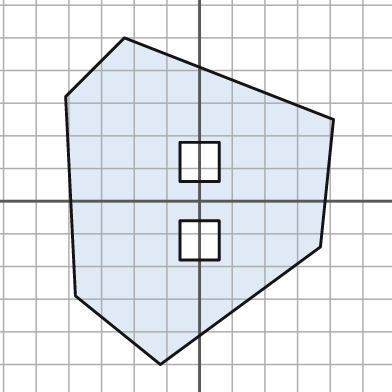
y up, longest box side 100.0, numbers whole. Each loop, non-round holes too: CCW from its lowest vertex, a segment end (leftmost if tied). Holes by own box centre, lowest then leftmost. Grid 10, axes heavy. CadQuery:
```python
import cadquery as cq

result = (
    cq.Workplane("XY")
    .moveTo(-12.0, -50.0)
    .lineTo(37.0, -14.0)
    .lineTo(41.0, 25.0)
    .lineTo(-23.0, 50.0)
    .lineTo(-41.0, 32.0)
    .lineTo(-38.0, -29.0)
    .close()
    .moveTo(-6.0, -18.0)
    .lineTo(6.0, -18.0)
    .lineTo(6.0, -6.0)
    .lineTo(-6.0, -6.0)
    .close()
    .moveTo(-6.0, 6.0)
    .lineTo(6.0, 6.0)
    .lineTo(6.0, 18.0)
    .lineTo(-6.0, 18.0)
    .close()
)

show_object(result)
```